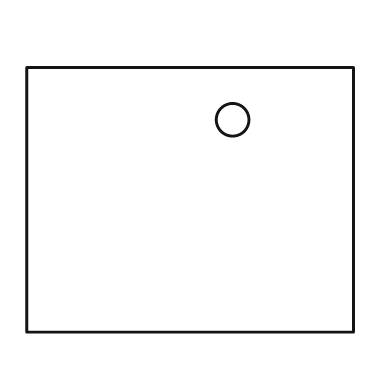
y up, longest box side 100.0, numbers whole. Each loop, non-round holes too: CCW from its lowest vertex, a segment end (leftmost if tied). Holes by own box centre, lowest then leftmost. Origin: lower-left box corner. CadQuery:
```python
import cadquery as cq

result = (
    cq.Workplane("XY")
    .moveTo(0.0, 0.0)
    .lineTo(100.0, 0.0)
    .lineTo(100.0, 81.0)
    .lineTo(0.0, 81.0)
    .close()
    .moveTo(63.0, 65.0)
    .circle(5.0)
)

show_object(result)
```